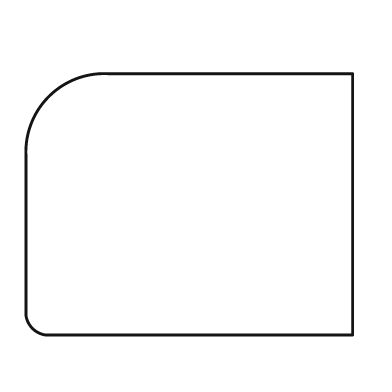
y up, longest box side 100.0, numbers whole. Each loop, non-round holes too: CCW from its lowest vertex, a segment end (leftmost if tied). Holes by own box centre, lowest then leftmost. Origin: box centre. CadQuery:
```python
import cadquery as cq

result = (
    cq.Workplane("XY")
    .moveTo(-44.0, -40.0)
    .lineTo(50.0, -40.0)
    .lineTo(50.0, 40.0)
    .lineTo(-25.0, 40.0)
    .threePointArc((-43.0, 33.0), (-50.0, 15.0))
    .lineTo(-50.0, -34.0)
    .threePointArc((-48.0, -38.0), (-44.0, -40.0))
    .close()
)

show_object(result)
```